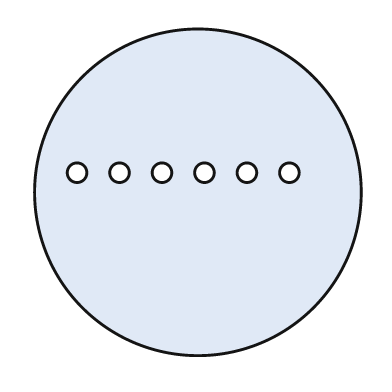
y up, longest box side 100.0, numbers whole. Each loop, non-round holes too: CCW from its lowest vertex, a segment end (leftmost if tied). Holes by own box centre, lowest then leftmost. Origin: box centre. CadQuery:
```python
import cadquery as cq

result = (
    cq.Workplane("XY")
    .moveTo(0.0, 0.0)
    .circle(50.0)
    .moveTo(-37.0, 6.0)
    .circle(3.0)
    .moveTo(-24.0, 6.0)
    .circle(3.0)
    .moveTo(-11.0, 6.0)
    .circle(3.0)
    .moveTo(2.0, 6.0)
    .circle(3.0)
    .moveTo(15.0, 6.0)
    .circle(3.0)
    .moveTo(28.0, 6.0)
    .circle(3.0)
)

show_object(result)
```